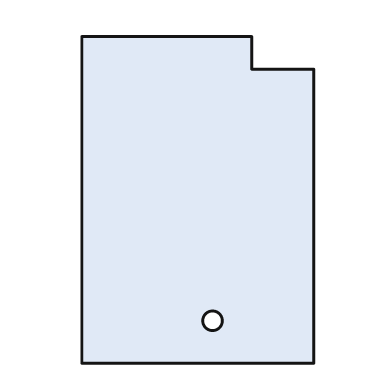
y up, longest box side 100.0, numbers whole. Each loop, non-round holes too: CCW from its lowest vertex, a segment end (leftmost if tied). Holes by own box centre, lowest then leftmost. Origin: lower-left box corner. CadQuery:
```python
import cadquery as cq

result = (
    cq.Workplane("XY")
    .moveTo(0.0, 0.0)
    .lineTo(71.0, 0.0)
    .lineTo(71.0, 90.0)
    .lineTo(52.0, 90.0)
    .lineTo(52.0, 100.0)
    .lineTo(0.0, 100.0)
    .close()
    .moveTo(40.0, 13.0)
    .circle(3.0)
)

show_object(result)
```